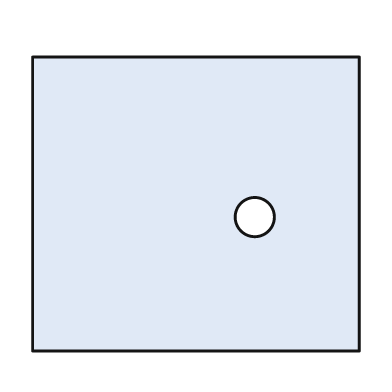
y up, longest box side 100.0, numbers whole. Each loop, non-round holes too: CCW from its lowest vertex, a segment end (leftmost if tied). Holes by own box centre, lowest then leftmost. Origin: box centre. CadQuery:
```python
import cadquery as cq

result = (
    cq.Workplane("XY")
    .moveTo(-50.0, -45.0)
    .lineTo(50.0, -45.0)
    .lineTo(50.0, 45.0)
    .lineTo(-50.0, 45.0)
    .close()
    .moveTo(18.0, -4.0)
    .circle(6.0)
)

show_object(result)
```